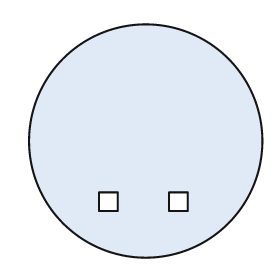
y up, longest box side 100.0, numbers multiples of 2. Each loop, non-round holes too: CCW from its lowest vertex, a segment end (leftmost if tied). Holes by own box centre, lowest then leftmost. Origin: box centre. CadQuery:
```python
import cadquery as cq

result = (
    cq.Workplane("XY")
    .moveTo(0.0, 0.0)
    .circle(50.0)
    .moveTo(-20.0, -30.0)
    .lineTo(-12.0, -30.0)
    .lineTo(-12.0, -22.0)
    .lineTo(-20.0, -22.0)
    .close()
    .moveTo(10.0, -30.0)
    .lineTo(18.0, -30.0)
    .lineTo(18.0, -22.0)
    .lineTo(10.0, -22.0)
    .close()
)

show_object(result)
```